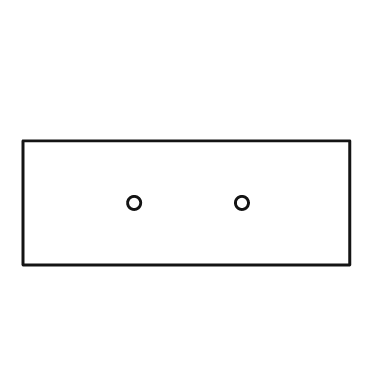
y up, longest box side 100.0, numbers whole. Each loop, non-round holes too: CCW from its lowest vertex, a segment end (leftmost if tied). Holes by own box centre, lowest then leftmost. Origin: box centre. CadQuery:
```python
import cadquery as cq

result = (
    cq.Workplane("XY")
    .moveTo(-50.0, -19.0)
    .lineTo(50.0, -19.0)
    .lineTo(50.0, 19.0)
    .lineTo(-50.0, 19.0)
    .close()
    .moveTo(-16.0, 0.0)
    .circle(2.0)
    .moveTo(17.0, 0.0)
    .circle(2.0)
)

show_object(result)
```